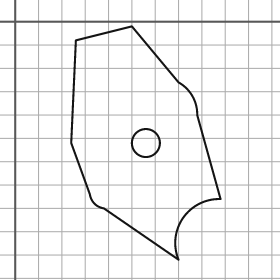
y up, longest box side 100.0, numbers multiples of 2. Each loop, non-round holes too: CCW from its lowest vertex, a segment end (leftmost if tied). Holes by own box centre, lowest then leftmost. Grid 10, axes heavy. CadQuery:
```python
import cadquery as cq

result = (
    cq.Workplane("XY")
    .moveTo(70.0, -102.0)
    .threePointArc((72.0, -84.0), (88.0, -76.0))
    .lineTo(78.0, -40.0)
    .threePointArc((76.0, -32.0), (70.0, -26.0))
    .lineTo(50.0, -2.0)
    .lineTo(26.0, -8.0)
    .lineTo(24.0, -52.0)
    .lineTo(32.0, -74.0)
    .threePointArc((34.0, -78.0), (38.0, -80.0))
    .close()
    .moveTo(56.0, -52.0)
    .circle(6.0)
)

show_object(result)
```